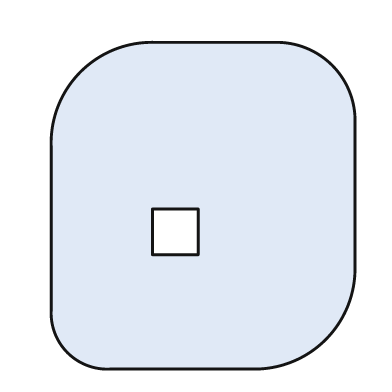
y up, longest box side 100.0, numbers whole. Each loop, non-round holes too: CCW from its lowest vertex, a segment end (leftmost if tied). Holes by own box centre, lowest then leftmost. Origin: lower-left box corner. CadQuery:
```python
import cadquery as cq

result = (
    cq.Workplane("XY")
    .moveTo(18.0, 0.0)
    .lineTo(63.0, 0.0)
    .threePointArc((84.0, 9.0), (93.0, 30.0))
    .lineTo(93.0, 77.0)
    .threePointArc((86.0, 93.0), (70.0, 100.0))
    .lineTo(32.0, 100.0)
    .threePointArc((9.0, 91.0), (0.0, 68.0))
    .lineTo(0.0, 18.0)
    .threePointArc((5.0, 5.0), (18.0, 0.0))
    .close()
    .moveTo(31.0, 35.0)
    .lineTo(45.0, 35.0)
    .lineTo(45.0, 49.0)
    .lineTo(31.0, 49.0)
    .close()
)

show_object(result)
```